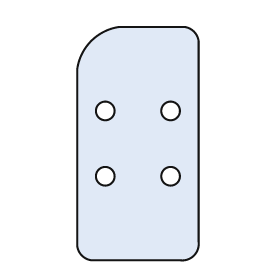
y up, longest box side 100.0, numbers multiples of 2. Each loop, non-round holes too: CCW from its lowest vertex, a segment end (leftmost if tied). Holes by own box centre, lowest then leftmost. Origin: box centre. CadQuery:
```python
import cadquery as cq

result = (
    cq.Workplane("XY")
    .moveTo(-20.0, -50.0)
    .lineTo(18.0, -50.0)
    .threePointArc((24.0, -48.0), (26.0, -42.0))
    .lineTo(26.0, 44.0)
    .threePointArc((24.0, 48.0), (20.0, 50.0))
    .lineTo(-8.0, 50.0)
    .threePointArc((-20.0, 44.0), (-26.0, 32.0))
    .lineTo(-26.0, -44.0)
    .threePointArc((-24.0, -48.0), (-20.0, -50.0))
    .close()
    .moveTo(-14.0, -14.0)
    .circle(4.0)
    .moveTo(14.0, -14.0)
    .circle(4.0)
    .moveTo(-14.0, 14.0)
    .circle(4.0)
    .moveTo(14.0, 14.0)
    .circle(4.0)
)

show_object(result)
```